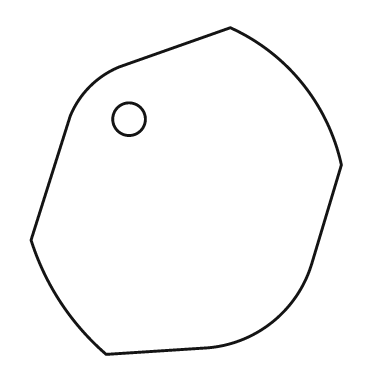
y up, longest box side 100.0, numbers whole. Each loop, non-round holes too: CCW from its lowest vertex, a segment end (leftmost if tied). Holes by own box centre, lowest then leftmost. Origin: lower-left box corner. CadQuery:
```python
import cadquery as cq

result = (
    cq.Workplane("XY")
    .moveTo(23.0, 0.0)
    .lineTo(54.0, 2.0)
    .threePointArc((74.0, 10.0), (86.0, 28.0))
    .lineTo(95.0, 58.0)
    .threePointArc((83.0, 83.0), (61.0, 100.0))
    .lineTo(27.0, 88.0)
    .threePointArc((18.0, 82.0), (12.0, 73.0))
    .lineTo(0.0, 35.0)
    .threePointArc((9.0, 16.0), (23.0, 0.0))
    .close()
    .moveTo(30.0, 72.0)
    .circle(5.0)
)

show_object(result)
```